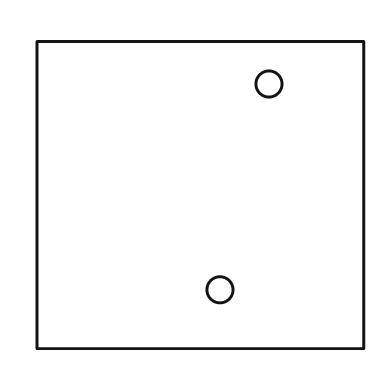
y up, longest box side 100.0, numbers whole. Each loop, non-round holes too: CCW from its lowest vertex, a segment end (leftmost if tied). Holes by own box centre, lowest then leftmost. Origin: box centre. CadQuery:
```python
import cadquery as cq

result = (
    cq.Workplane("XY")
    .moveTo(-50.0, -47.0)
    .lineTo(50.0, -47.0)
    .lineTo(50.0, 47.0)
    .lineTo(-50.0, 47.0)
    .close()
    .moveTo(6.0, -29.0)
    .circle(4.0)
    .moveTo(21.0, 34.0)
    .circle(4.0)
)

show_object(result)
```